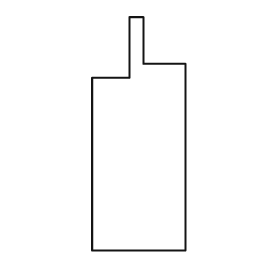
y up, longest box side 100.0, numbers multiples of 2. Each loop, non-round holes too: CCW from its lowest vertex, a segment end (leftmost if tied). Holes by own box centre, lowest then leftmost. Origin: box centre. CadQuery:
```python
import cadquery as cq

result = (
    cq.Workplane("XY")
    .moveTo(-20.0, -50.0)
    .lineTo(20.0, -50.0)
    .lineTo(20.0, 30.0)
    .lineTo(2.0, 30.0)
    .lineTo(2.0, 50.0)
    .lineTo(-4.0, 50.0)
    .lineTo(-4.0, 24.0)
    .lineTo(-20.0, 24.0)
    .close()
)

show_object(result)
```